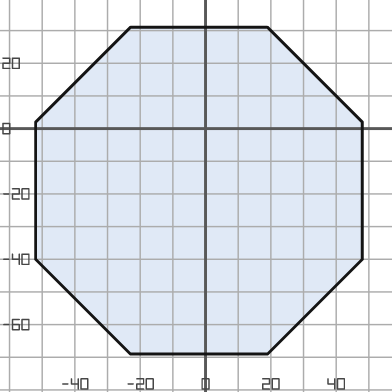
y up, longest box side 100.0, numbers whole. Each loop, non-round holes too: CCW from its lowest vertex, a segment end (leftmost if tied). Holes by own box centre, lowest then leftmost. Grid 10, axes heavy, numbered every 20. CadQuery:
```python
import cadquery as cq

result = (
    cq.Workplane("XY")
    .moveTo(-23.0, -69.0)
    .lineTo(19.0, -69.0)
    .lineTo(48.0, -40.0)
    .lineTo(48.0, 2.0)
    .lineTo(19.0, 31.0)
    .lineTo(-23.0, 31.0)
    .lineTo(-52.0, 2.0)
    .lineTo(-52.0, -40.0)
    .close()
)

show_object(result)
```